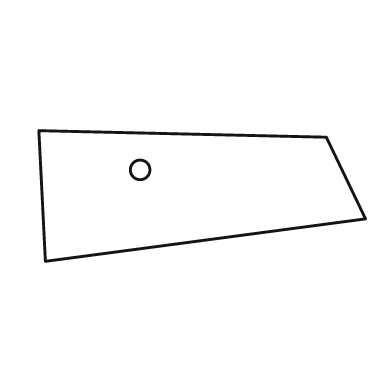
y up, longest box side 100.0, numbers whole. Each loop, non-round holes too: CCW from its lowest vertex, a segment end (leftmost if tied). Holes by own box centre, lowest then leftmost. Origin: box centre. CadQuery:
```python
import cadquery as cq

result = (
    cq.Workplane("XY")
    .moveTo(-48.0, -20.0)
    .lineTo(50.0, -7.0)
    .lineTo(38.0, 18.0)
    .lineTo(-50.0, 20.0)
    .close()
    .moveTo(-19.0, 8.0)
    .circle(3.0)
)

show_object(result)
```